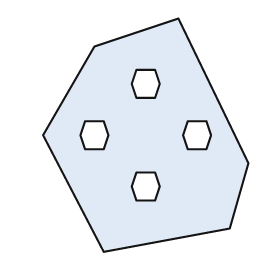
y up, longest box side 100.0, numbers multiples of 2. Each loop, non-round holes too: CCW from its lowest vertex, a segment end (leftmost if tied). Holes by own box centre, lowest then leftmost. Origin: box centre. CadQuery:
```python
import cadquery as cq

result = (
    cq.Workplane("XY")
    .moveTo(-18.0, -50.0)
    .lineTo(36.0, -40.0)
    .lineTo(44.0, -12.0)
    .lineTo(14.0, 50.0)
    .lineTo(-22.0, 38.0)
    .lineTo(-44.0, 0.0)
    .close()
    .moveTo(-4.0, -28.0)
    .lineTo(4.0, -28.0)
    .lineTo(6.0, -22.0)
    .lineTo(4.0, -16.0)
    .lineTo(-4.0, -16.0)
    .lineTo(-6.0, -22.0)
    .close()
    .moveTo(-26.0, -6.0)
    .lineTo(-18.0, -6.0)
    .lineTo(-16.0, 0.0)
    .lineTo(-18.0, 6.0)
    .lineTo(-26.0, 6.0)
    .lineTo(-28.0, 0.0)
    .close()
    .moveTo(18.0, -6.0)
    .lineTo(26.0, -6.0)
    .lineTo(28.0, 0.0)
    .lineTo(26.0, 6.0)
    .lineTo(18.0, 6.0)
    .lineTo(16.0, 0.0)
    .close()
    .moveTo(-4.0, 16.0)
    .lineTo(4.0, 16.0)
    .lineTo(6.0, 22.0)
    .lineTo(4.0, 28.0)
    .lineTo(-4.0, 28.0)
    .lineTo(-6.0, 22.0)
    .close()
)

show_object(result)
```